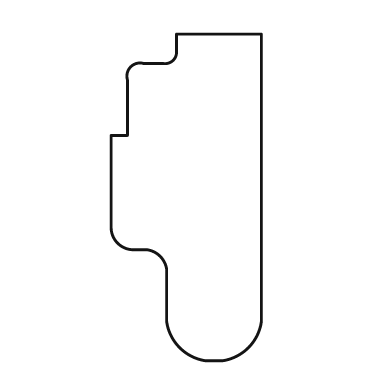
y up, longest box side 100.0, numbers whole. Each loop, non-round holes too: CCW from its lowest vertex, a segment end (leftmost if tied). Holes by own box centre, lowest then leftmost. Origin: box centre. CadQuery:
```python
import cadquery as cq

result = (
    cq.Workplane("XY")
    .moveTo(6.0, -50.0)
    .lineTo(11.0, -50.0)
    .threePointArc((19.0, -46.0), (23.0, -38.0))
    .lineTo(23.0, 50.0)
    .lineTo(-3.0, 50.0)
    .lineTo(-3.0, 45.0)
    .threePointArc((-4.0, 42.0), (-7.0, 41.0))
    .lineTo(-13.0, 41.0)
    .threePointArc((-17.0, 40.0), (-18.0, 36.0))
    .lineTo(-18.0, 19.0)
    .lineTo(-23.0, 19.0)
    .lineTo(-23.0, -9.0)
    .threePointArc((-21.0, -14.0), (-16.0, -16.0))
    .lineTo(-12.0, -16.0)
    .threePointArc((-8.0, -18.0), (-6.0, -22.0))
    .lineTo(-6.0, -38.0)
    .threePointArc((-2.0, -46.0), (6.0, -50.0))
    .close()
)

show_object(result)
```